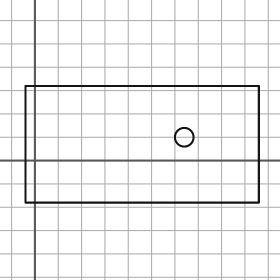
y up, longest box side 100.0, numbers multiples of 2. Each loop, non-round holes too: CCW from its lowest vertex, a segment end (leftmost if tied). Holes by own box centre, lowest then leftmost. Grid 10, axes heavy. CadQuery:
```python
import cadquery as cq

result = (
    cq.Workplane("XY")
    .moveTo(-4.0, -18.0)
    .lineTo(96.0, -18.0)
    .lineTo(96.0, 32.0)
    .lineTo(-4.0, 32.0)
    .close()
    .moveTo(64.0, 10.0)
    .circle(4.0)
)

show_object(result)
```